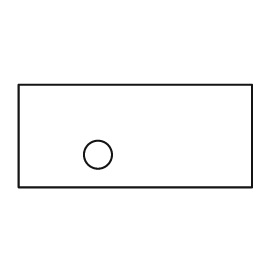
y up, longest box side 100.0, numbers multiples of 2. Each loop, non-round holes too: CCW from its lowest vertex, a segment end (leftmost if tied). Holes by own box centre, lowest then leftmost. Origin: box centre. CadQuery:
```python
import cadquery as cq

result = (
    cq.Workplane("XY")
    .moveTo(-50.0, -22.0)
    .lineTo(50.0, -22.0)
    .lineTo(50.0, 22.0)
    .lineTo(-50.0, 22.0)
    .close()
    .moveTo(-16.0, -8.0)
    .circle(6.0)
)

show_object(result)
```